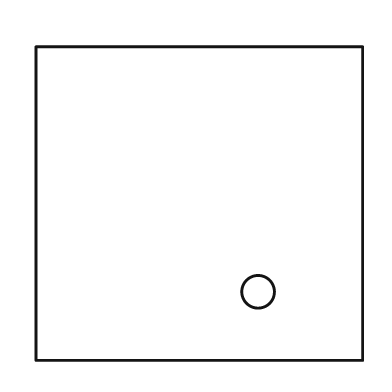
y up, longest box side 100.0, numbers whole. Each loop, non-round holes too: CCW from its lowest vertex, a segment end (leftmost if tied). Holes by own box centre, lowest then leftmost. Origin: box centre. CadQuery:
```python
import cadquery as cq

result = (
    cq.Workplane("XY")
    .moveTo(-50.0, -48.0)
    .lineTo(50.0, -48.0)
    .lineTo(50.0, 48.0)
    .lineTo(-50.0, 48.0)
    .close()
    .moveTo(18.0, -27.0)
    .circle(5.0)
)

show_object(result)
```